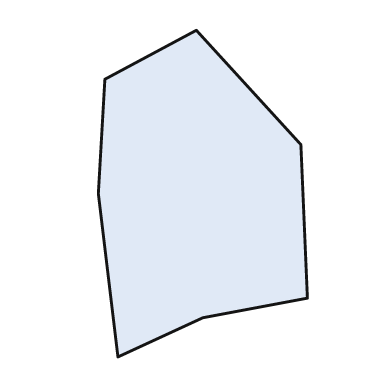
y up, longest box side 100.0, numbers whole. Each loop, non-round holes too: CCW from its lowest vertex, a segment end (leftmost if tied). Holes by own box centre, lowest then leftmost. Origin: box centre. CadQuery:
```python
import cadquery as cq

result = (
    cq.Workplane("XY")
    .moveTo(-26.0, -50.0)
    .lineTo(0.0, -38.0)
    .lineTo(32.0, -32.0)
    .lineTo(30.0, 15.0)
    .lineTo(-2.0, 50.0)
    .lineTo(-30.0, 35.0)
    .lineTo(-32.0, 0.0)
    .close()
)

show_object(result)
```